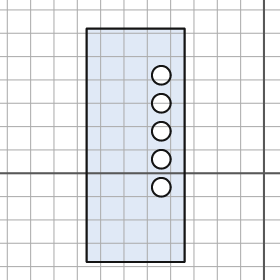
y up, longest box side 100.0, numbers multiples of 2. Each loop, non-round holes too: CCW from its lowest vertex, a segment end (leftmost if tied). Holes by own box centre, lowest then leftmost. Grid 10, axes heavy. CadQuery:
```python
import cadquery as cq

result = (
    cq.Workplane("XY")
    .moveTo(-76.0, -38.0)
    .lineTo(-34.0, -38.0)
    .lineTo(-34.0, 62.0)
    .lineTo(-76.0, 62.0)
    .close()
    .moveTo(-44.0, -6.0)
    .circle(4.0)
    .moveTo(-44.0, 6.0)
    .circle(4.0)
    .moveTo(-44.0, 18.0)
    .circle(4.0)
    .moveTo(-44.0, 30.0)
    .circle(4.0)
    .moveTo(-44.0, 42.0)
    .circle(4.0)
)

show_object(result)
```